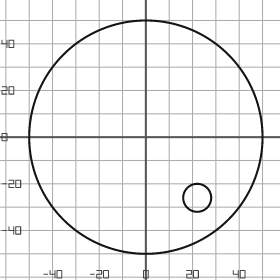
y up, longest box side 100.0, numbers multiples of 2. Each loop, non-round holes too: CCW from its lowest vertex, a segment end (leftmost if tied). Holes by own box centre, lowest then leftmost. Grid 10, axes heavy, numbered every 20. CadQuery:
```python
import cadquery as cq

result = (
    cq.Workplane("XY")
    .moveTo(0.0, 0.0)
    .circle(50.0)
    .moveTo(22.0, -26.0)
    .circle(6.0)
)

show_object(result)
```